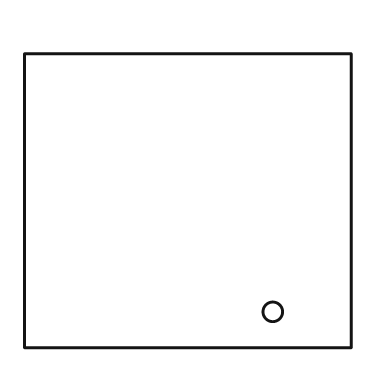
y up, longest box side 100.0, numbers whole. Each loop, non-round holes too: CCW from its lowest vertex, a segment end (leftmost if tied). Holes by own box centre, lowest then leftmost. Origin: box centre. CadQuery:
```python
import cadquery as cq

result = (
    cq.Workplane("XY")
    .moveTo(-50.0, -45.0)
    .lineTo(50.0, -45.0)
    .lineTo(50.0, 45.0)
    .lineTo(-50.0, 45.0)
    .close()
    .moveTo(26.0, -34.0)
    .circle(3.0)
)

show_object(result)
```